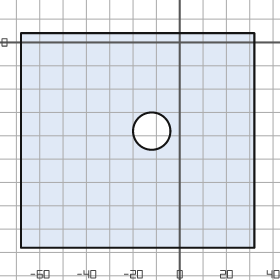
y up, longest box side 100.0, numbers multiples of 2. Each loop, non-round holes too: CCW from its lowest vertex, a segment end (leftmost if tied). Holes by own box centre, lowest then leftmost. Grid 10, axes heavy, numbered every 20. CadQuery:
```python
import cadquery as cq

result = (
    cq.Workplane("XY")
    .moveTo(-68.0, -88.0)
    .lineTo(32.0, -88.0)
    .lineTo(32.0, 4.0)
    .lineTo(-68.0, 4.0)
    .close()
    .moveTo(-12.0, -38.0)
    .circle(8.0)
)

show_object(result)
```